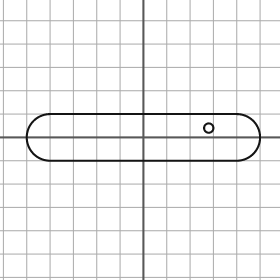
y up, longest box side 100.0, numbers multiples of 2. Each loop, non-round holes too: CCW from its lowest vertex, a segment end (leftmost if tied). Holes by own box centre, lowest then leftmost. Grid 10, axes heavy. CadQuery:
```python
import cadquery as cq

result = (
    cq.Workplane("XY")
    .moveTo(-40.0, -10.0)
    .lineTo(40.0, -10.0)
    .threePointArc((50.0, 0.0), (40.0, 10.0))
    .lineTo(-40.0, 10.0)
    .threePointArc((-50.0, 0.0), (-40.0, -10.0))
    .close()
    .moveTo(28.0, 4.0)
    .circle(2.0)
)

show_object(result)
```